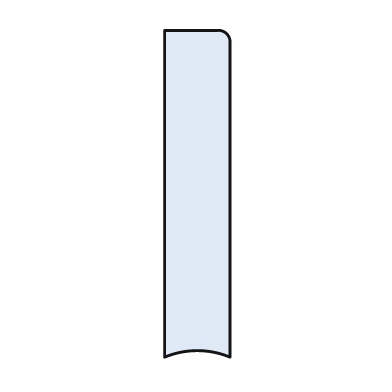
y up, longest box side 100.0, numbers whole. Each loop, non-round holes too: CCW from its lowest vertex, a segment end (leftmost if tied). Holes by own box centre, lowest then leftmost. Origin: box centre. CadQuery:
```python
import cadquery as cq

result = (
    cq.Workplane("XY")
    .moveTo(-10.0, -50.0)
    .threePointArc((0.0, -48.0), (10.0, -50.0))
    .lineTo(10.0, 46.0)
    .threePointArc((9.0, 49.0), (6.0, 50.0))
    .lineTo(-10.0, 50.0)
    .close()
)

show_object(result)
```